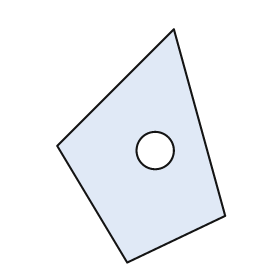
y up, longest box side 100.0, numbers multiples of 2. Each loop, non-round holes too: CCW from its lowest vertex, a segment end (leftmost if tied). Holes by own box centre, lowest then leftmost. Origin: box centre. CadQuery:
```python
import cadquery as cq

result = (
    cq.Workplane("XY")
    .moveTo(-6.0, -50.0)
    .lineTo(36.0, -30.0)
    .lineTo(14.0, 50.0)
    .lineTo(-36.0, 0.0)
    .close()
    .moveTo(6.0, -2.0)
    .circle(8.0)
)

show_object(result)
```